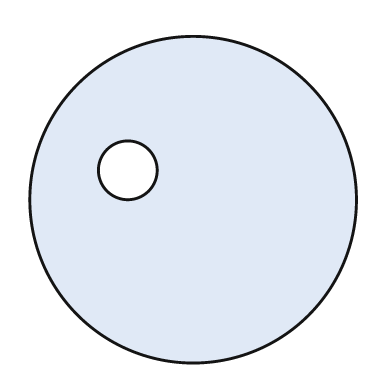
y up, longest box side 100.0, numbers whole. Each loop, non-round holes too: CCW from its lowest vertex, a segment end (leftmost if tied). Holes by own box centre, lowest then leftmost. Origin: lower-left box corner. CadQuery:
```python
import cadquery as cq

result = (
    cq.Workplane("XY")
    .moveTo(50.0, 50.0)
    .circle(50.0)
    .moveTo(30.0, 59.0)
    .circle(9.0)
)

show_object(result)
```